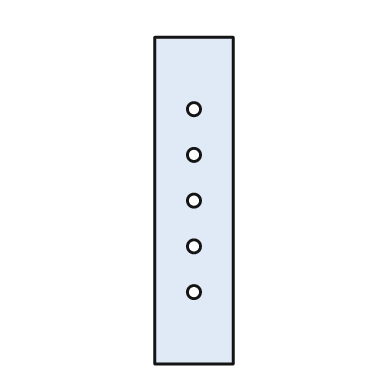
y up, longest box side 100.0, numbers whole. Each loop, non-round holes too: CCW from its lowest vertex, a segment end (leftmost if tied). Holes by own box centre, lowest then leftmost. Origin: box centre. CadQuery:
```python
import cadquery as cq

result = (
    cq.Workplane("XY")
    .moveTo(-12.0, -50.0)
    .lineTo(12.0, -50.0)
    .lineTo(12.0, 50.0)
    .lineTo(-12.0, 50.0)
    .close()
    .moveTo(0.0, -28.0)
    .circle(2.0)
    .moveTo(0.0, -14.0)
    .circle(2.0)
    .moveTo(0.0, 0.0)
    .circle(2.0)
    .moveTo(0.0, 14.0)
    .circle(2.0)
    .moveTo(0.0, 28.0)
    .circle(2.0)
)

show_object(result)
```